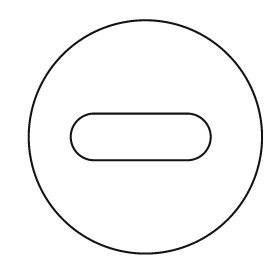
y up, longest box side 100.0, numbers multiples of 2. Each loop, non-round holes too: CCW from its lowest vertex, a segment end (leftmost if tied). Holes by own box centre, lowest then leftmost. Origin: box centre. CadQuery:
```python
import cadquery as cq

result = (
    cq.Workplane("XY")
    .moveTo(0.0, 0.0)
    .circle(50.0)
    .moveTo(-22.0, -10.0)
    .lineTo(18.0, -10.0)
    .threePointArc((28.0, 0.0), (18.0, 10.0))
    .lineTo(-22.0, 10.0)
    .threePointArc((-32.0, 0.0), (-22.0, -10.0))
    .close()
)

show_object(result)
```